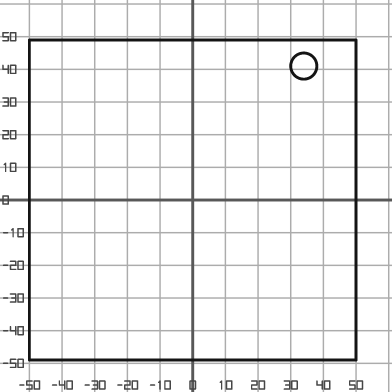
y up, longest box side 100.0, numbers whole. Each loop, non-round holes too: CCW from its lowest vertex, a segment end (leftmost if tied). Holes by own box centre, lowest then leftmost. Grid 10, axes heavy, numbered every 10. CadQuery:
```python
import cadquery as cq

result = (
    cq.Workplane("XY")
    .moveTo(-50.0, -49.0)
    .lineTo(50.0, -49.0)
    .lineTo(50.0, 49.0)
    .lineTo(-50.0, 49.0)
    .close()
    .moveTo(34.0, 41.0)
    .circle(4.0)
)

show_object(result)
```